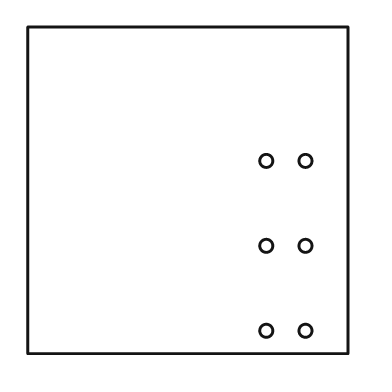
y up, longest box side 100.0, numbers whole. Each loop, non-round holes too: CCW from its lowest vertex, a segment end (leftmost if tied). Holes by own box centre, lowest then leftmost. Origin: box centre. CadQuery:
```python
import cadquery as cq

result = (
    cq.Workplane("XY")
    .moveTo(-49.0, -50.0)
    .lineTo(49.0, -50.0)
    .lineTo(49.0, 50.0)
    .lineTo(-49.0, 50.0)
    .close()
    .moveTo(24.0, -43.0)
    .circle(2.0)
    .moveTo(36.0, -43.0)
    .circle(2.0)
    .moveTo(24.0, -17.0)
    .circle(2.0)
    .moveTo(36.0, -17.0)
    .circle(2.0)
    .moveTo(24.0, 9.0)
    .circle(2.0)
    .moveTo(36.0, 9.0)
    .circle(2.0)
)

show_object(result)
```